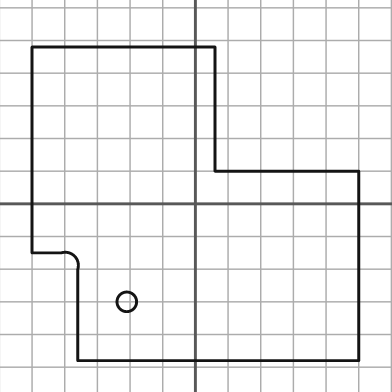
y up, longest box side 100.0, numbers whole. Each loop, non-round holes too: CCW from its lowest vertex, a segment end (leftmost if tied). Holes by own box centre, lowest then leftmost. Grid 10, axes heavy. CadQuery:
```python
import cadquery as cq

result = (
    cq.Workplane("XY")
    .moveTo(-36.0, -48.0)
    .lineTo(50.0, -48.0)
    .lineTo(50.0, 10.0)
    .lineTo(6.0, 10.0)
    .lineTo(6.0, 48.0)
    .lineTo(-50.0, 48.0)
    .lineTo(-50.0, -15.0)
    .lineTo(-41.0, -15.0)
    .threePointArc((-37.0, -16.0), (-36.0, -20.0))
    .close()
    .moveTo(-21.0, -30.0)
    .circle(3.0)
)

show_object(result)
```